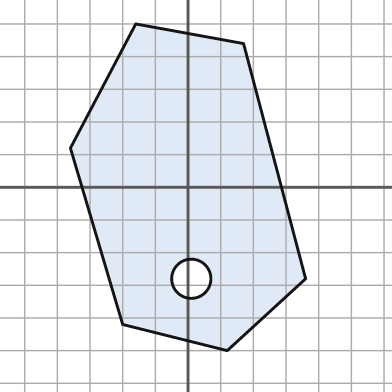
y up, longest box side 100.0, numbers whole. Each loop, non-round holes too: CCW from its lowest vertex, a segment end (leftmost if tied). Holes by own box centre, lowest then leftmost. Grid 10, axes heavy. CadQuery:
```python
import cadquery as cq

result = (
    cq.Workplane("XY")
    .moveTo(12.0, -50.0)
    .lineTo(36.0, -28.0)
    .lineTo(17.0, 44.0)
    .lineTo(-16.0, 50.0)
    .lineTo(-36.0, 12.0)
    .lineTo(-20.0, -42.0)
    .close()
    .moveTo(1.0, -28.0)
    .circle(6.0)
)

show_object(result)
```